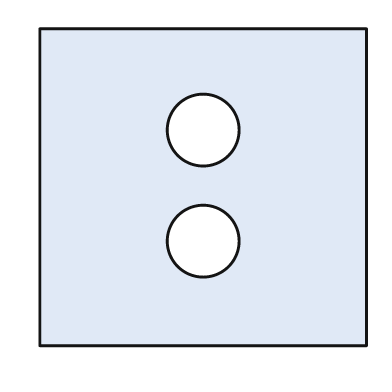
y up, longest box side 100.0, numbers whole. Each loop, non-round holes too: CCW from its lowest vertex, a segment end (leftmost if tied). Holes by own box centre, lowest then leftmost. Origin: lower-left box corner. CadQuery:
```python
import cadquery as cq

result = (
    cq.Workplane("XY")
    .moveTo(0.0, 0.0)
    .lineTo(100.0, 0.0)
    .lineTo(100.0, 97.0)
    .lineTo(0.0, 97.0)
    .close()
    .moveTo(50.0, 32.0)
    .circle(11.0)
    .moveTo(50.0, 66.0)
    .circle(11.0)
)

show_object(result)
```